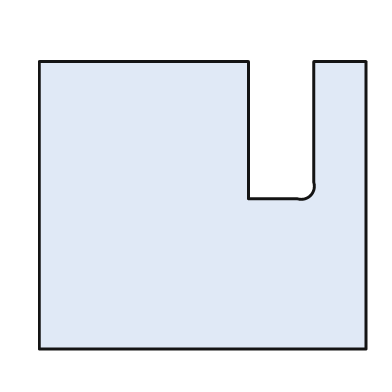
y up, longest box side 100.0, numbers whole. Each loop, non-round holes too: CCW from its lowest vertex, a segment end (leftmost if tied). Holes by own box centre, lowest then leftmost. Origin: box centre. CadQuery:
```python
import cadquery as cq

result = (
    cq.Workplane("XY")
    .moveTo(-50.0, -44.0)
    .lineTo(50.0, -44.0)
    .lineTo(50.0, 44.0)
    .lineTo(34.0, 44.0)
    .lineTo(34.0, 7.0)
    .threePointArc((33.0, 3.0), (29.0, 2.0))
    .lineTo(14.0, 2.0)
    .lineTo(14.0, 44.0)
    .lineTo(-50.0, 44.0)
    .close()
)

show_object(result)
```